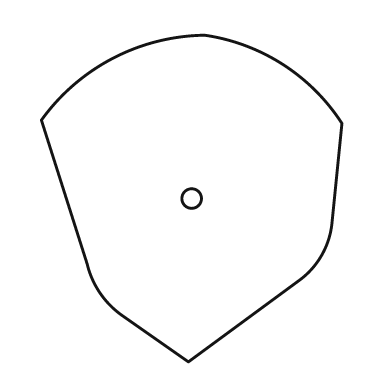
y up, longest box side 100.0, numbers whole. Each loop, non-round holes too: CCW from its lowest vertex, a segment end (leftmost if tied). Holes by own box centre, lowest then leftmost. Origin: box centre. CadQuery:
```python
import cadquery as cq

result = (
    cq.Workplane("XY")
    .moveTo(-1.0, -50.0)
    .lineTo(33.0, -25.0)
    .threePointArc((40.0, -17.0), (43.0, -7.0))
    .lineTo(46.0, 23.0)
    .threePointArc((28.0, 41.0), (4.0, 50.0))
    .threePointArc((-24.0, 43.0), (-46.0, 24.0))
    .lineTo(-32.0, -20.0)
    .threePointArc((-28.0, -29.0), (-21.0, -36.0))
    .close()
    .moveTo(0.0, 0.0)
    .circle(3.0)
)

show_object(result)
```